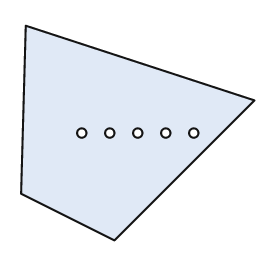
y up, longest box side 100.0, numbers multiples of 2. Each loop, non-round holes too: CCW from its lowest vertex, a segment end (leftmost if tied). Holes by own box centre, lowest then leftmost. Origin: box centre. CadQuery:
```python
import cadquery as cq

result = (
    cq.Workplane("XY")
    .moveTo(-10.0, -46.0)
    .lineTo(50.0, 14.0)
    .lineTo(-48.0, 46.0)
    .lineTo(-50.0, -26.0)
    .close()
    .moveTo(-24.0, 0.0)
    .circle(2.0)
    .moveTo(-12.0, 0.0)
    .circle(2.0)
    .moveTo(0.0, 0.0)
    .circle(2.0)
    .moveTo(12.0, 0.0)
    .circle(2.0)
    .moveTo(24.0, 0.0)
    .circle(2.0)
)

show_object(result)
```